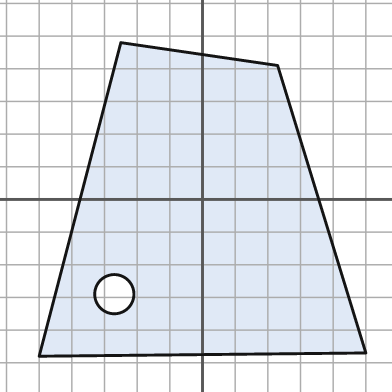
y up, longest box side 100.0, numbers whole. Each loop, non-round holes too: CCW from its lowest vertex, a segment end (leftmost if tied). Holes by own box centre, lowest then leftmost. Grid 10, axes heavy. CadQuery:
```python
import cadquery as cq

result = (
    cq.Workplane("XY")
    .moveTo(-50.0, -48.0)
    .lineTo(50.0, -47.0)
    .lineTo(23.0, 41.0)
    .lineTo(-25.0, 48.0)
    .close()
    .moveTo(-27.0, -29.0)
    .circle(6.0)
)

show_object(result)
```